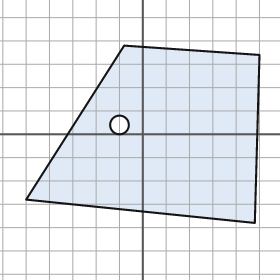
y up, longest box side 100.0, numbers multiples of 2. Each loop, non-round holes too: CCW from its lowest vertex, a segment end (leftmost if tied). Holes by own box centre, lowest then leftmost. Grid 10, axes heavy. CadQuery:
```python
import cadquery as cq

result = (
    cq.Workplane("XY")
    .moveTo(48.0, -38.0)
    .lineTo(50.0, 34.0)
    .lineTo(-8.0, 38.0)
    .lineTo(-50.0, -28.0)
    .close()
    .moveTo(-10.0, 4.0)
    .circle(4.0)
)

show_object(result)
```